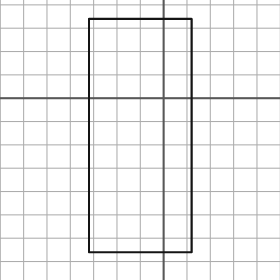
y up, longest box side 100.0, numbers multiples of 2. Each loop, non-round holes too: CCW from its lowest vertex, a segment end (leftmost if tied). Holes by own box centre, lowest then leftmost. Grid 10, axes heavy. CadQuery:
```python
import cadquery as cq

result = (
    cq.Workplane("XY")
    .moveTo(-32.0, -66.0)
    .lineTo(12.0, -66.0)
    .lineTo(12.0, 34.0)
    .lineTo(-32.0, 34.0)
    .close()
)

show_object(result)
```